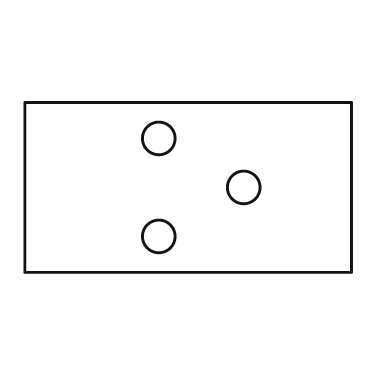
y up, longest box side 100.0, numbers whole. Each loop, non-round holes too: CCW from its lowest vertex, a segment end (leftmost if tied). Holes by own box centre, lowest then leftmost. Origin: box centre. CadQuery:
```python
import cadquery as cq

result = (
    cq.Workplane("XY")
    .moveTo(-50.0, -26.0)
    .lineTo(50.0, -26.0)
    .lineTo(50.0, 26.0)
    .lineTo(-50.0, 26.0)
    .close()
    .moveTo(-9.0, -15.0)
    .circle(5.0)
    .moveTo(17.0, 0.0)
    .circle(5.0)
    .moveTo(-9.0, 15.0)
    .circle(5.0)
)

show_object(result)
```